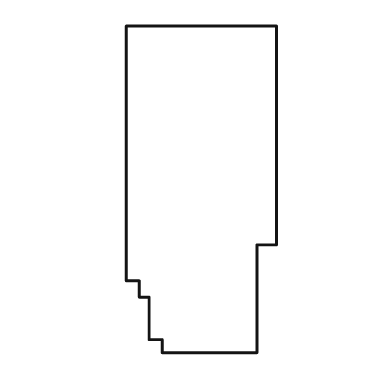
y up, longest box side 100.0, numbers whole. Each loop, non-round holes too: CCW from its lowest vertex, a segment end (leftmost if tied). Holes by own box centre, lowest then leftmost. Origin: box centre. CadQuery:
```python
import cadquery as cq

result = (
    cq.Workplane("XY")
    .moveTo(-12.0, -50.0)
    .lineTo(17.0, -50.0)
    .lineTo(17.0, -17.0)
    .lineTo(23.0, -17.0)
    .lineTo(23.0, 50.0)
    .lineTo(-23.0, 50.0)
    .lineTo(-23.0, -28.0)
    .lineTo(-19.0, -28.0)
    .lineTo(-19.0, -33.0)
    .lineTo(-16.0, -33.0)
    .lineTo(-16.0, -46.0)
    .lineTo(-12.0, -46.0)
    .close()
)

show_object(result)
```